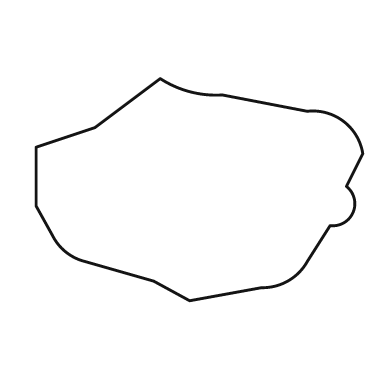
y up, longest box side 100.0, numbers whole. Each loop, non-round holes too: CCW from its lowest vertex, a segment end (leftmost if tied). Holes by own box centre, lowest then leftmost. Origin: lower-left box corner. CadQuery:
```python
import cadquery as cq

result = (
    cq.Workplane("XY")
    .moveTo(47.0, 0.0)
    .lineTo(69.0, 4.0)
    .threePointArc((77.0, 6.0), (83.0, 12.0))
    .lineTo(90.0, 23.0)
    .threePointArc((97.0, 27.0), (95.0, 35.0))
    .lineTo(100.0, 45.0)
    .threePointArc((94.0, 55.0), (83.0, 58.0))
    .lineTo(57.0, 63.0)
    .threePointArc((47.0, 64.0), (38.0, 68.0))
    .lineTo(18.0, 53.0)
    .lineTo(0.0, 47.0)
    .lineTo(0.0, 29.0)
    .lineTo(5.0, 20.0)
    .threePointArc((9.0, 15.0), (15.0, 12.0))
    .lineTo(36.0, 6.0)
    .close()
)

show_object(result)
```